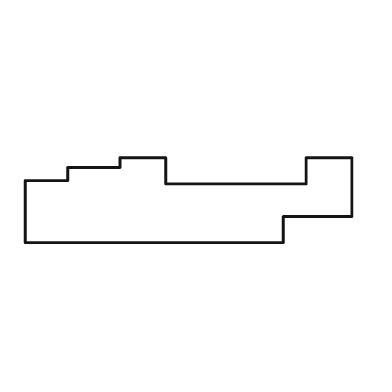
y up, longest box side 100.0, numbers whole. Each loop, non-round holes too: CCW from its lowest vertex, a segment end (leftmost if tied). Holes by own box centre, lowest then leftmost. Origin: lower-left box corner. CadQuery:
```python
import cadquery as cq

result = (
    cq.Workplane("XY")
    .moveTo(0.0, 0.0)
    .lineTo(79.0, 0.0)
    .lineTo(79.0, 8.0)
    .lineTo(100.0, 8.0)
    .lineTo(100.0, 26.0)
    .lineTo(86.0, 26.0)
    .lineTo(86.0, 18.0)
    .lineTo(43.0, 18.0)
    .lineTo(43.0, 26.0)
    .lineTo(29.0, 26.0)
    .lineTo(29.0, 23.0)
    .lineTo(13.0, 23.0)
    .lineTo(13.0, 19.0)
    .lineTo(0.0, 19.0)
    .close()
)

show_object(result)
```